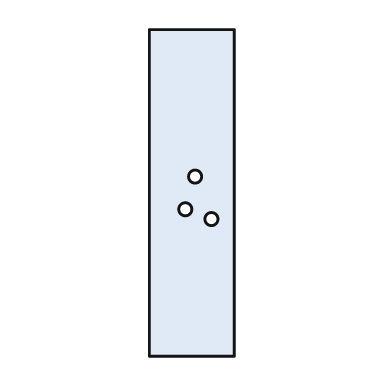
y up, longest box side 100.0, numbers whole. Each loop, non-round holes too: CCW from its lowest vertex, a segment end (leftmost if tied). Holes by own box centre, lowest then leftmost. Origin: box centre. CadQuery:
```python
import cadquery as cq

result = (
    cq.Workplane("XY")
    .moveTo(-13.0, -50.0)
    .lineTo(13.0, -50.0)
    .lineTo(13.0, 50.0)
    .lineTo(-13.0, 50.0)
    .close()
    .moveTo(6.0, -8.0)
    .circle(2.0)
    .moveTo(-2.0, -5.0)
    .circle(2.0)
    .moveTo(1.0, 5.0)
    .circle(2.0)
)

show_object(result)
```